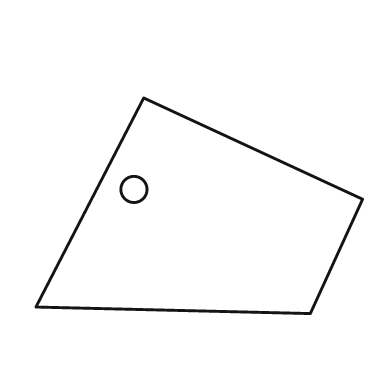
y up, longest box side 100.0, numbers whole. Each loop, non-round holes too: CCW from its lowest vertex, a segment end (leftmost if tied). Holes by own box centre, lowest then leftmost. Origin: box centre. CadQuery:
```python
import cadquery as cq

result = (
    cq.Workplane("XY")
    .moveTo(34.0, -33.0)
    .lineTo(50.0, 2.0)
    .lineTo(-17.0, 33.0)
    .lineTo(-50.0, -31.0)
    .close()
    .moveTo(-20.0, 5.0)
    .circle(4.0)
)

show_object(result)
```